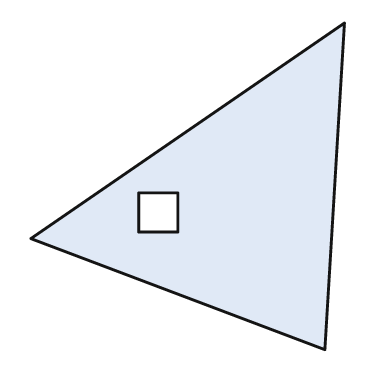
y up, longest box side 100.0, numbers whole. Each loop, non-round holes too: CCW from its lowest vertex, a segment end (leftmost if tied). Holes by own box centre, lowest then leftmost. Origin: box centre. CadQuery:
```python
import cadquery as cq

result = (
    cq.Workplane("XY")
    .moveTo(42.0, -50.0)
    .lineTo(48.0, 50.0)
    .lineTo(-48.0, -16.0)
    .close()
    .moveTo(-15.0, -14.0)
    .lineTo(-3.0, -14.0)
    .lineTo(-3.0, -2.0)
    .lineTo(-15.0, -2.0)
    .close()
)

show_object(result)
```